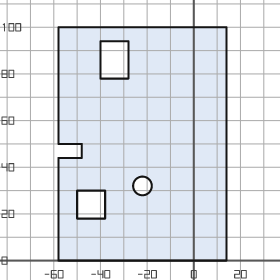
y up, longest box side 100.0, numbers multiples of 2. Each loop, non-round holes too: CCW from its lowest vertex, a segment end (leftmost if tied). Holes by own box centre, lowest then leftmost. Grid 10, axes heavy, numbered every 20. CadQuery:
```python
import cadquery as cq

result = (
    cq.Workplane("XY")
    .moveTo(-58.0, 0.0)
    .lineTo(14.0, 0.0)
    .lineTo(14.0, 100.0)
    .lineTo(-58.0, 100.0)
    .lineTo(-58.0, 50.0)
    .lineTo(-48.0, 50.0)
    .lineTo(-48.0, 44.0)
    .lineTo(-58.0, 44.0)
    .close()
    .moveTo(-50.0, 18.0)
    .lineTo(-38.0, 18.0)
    .lineTo(-38.0, 30.0)
    .lineTo(-50.0, 30.0)
    .close()
    .moveTo(-22.0, 32.0)
    .circle(4.0)
    .moveTo(-40.0, 78.0)
    .lineTo(-28.0, 78.0)
    .lineTo(-28.0, 94.0)
    .lineTo(-40.0, 94.0)
    .close()
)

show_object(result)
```